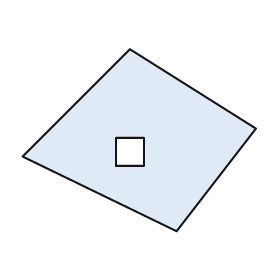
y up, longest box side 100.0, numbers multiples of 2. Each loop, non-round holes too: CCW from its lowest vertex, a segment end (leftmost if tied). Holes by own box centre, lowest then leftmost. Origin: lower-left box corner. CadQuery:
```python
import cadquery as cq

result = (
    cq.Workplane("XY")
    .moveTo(66.0, 0.0)
    .lineTo(100.0, 44.0)
    .lineTo(46.0, 78.0)
    .lineTo(0.0, 32.0)
    .close()
    .moveTo(40.0, 28.0)
    .lineTo(52.0, 28.0)
    .lineTo(52.0, 40.0)
    .lineTo(40.0, 40.0)
    .close()
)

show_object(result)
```